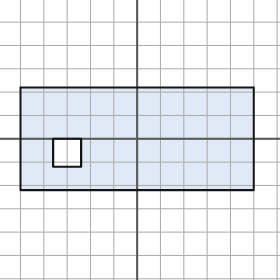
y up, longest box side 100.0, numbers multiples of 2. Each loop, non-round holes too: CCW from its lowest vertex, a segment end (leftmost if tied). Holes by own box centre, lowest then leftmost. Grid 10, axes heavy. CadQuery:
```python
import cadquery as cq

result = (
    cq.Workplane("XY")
    .moveTo(-50.0, -22.0)
    .lineTo(50.0, -22.0)
    .lineTo(50.0, 22.0)
    .lineTo(-50.0, 22.0)
    .close()
    .moveTo(-36.0, -12.0)
    .lineTo(-24.0, -12.0)
    .lineTo(-24.0, 0.0)
    .lineTo(-36.0, 0.0)
    .close()
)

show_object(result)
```